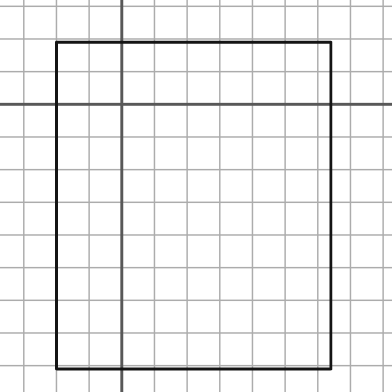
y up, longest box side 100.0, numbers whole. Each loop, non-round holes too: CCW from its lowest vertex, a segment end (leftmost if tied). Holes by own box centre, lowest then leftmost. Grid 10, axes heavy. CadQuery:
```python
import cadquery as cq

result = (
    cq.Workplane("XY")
    .moveTo(-20.0, -81.0)
    .lineTo(64.0, -81.0)
    .lineTo(64.0, 19.0)
    .lineTo(-20.0, 19.0)
    .close()
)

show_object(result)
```